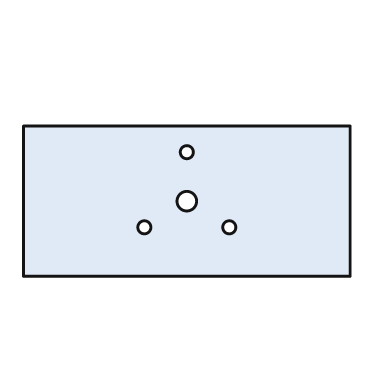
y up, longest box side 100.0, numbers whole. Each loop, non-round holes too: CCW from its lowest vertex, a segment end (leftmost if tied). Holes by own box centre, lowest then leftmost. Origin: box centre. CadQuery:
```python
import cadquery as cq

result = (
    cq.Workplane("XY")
    .moveTo(-50.0, -23.0)
    .lineTo(50.0, -23.0)
    .lineTo(50.0, 23.0)
    .lineTo(-50.0, 23.0)
    .close()
    .moveTo(-13.0, -8.0)
    .circle(2.0)
    .moveTo(13.0, -8.0)
    .circle(2.0)
    .moveTo(0.0, 0.0)
    .circle(3.0)
    .moveTo(0.0, 15.0)
    .circle(2.0)
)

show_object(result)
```